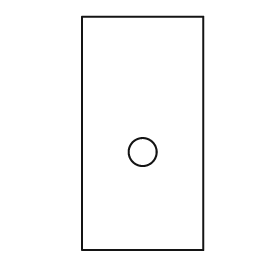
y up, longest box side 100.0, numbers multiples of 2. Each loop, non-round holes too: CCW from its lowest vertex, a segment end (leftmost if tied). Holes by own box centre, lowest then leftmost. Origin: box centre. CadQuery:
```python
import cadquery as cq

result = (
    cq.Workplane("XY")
    .moveTo(-26.0, -50.0)
    .lineTo(26.0, -50.0)
    .lineTo(26.0, 50.0)
    .lineTo(-26.0, 50.0)
    .close()
    .moveTo(0.0, -8.0)
    .circle(6.0)
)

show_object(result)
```